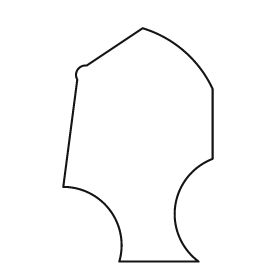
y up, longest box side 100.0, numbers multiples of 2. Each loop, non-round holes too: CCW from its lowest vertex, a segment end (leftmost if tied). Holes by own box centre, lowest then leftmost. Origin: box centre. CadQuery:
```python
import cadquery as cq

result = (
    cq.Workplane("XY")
    .moveTo(-8.0, -50.0)
    .lineTo(26.0, -50.0)
    .threePointArc((16.0, -26.0), (32.0, -6.0))
    .lineTo(32.0, 24.0)
    .threePointArc((20.0, 40.0), (2.0, 50.0))
    .lineTo(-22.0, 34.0)
    .threePointArc((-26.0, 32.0), (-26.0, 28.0))
    .lineTo(-32.0, -18.0)
    .threePointArc((-12.0, -28.0), (-8.0, -50.0))
    .close()
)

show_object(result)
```